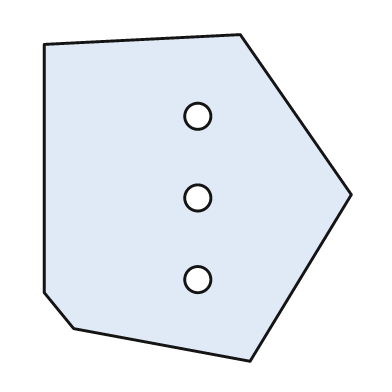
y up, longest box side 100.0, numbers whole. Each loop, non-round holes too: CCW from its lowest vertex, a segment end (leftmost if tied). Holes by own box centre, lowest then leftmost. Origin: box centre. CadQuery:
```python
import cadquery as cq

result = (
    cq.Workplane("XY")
    .moveTo(16.0, -50.0)
    .lineTo(47.0, 1.0)
    .lineTo(13.0, 50.0)
    .lineTo(-47.0, 47.0)
    .lineTo(-47.0, -29.0)
    .lineTo(-38.0, -40.0)
    .close()
    .moveTo(0.0, -25.0)
    .circle(4.0)
    .moveTo(0.0, 0.0)
    .circle(4.0)
    .moveTo(0.0, 25.0)
    .circle(4.0)
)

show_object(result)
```